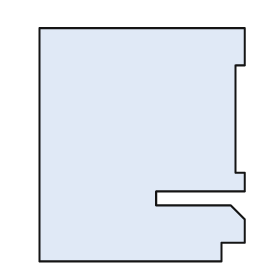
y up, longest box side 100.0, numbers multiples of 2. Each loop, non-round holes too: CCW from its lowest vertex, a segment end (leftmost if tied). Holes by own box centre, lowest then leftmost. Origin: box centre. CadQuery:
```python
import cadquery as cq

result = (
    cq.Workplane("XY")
    .moveTo(-44.0, -50.0)
    .lineTo(34.0, -50.0)
    .lineTo(34.0, -42.0)
    .lineTo(44.0, -42.0)
    .lineTo(44.0, -32.0)
    .lineTo(38.0, -26.0)
    .lineTo(6.0, -26.0)
    .lineTo(6.0, -20.0)
    .lineTo(44.0, -20.0)
    .lineTo(44.0, -12.0)
    .lineTo(40.0, -12.0)
    .lineTo(40.0, 34.0)
    .lineTo(44.0, 34.0)
    .lineTo(44.0, 50.0)
    .lineTo(-44.0, 50.0)
    .close()
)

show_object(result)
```